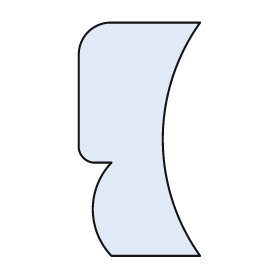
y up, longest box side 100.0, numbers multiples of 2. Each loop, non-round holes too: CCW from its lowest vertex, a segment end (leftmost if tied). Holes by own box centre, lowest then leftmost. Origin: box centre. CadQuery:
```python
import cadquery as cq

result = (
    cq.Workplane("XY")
    .moveTo(-12.0, -50.0)
    .lineTo(26.0, -50.0)
    .threePointArc((10.0, 0.0), (26.0, 50.0))
    .lineTo(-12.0, 50.0)
    .threePointArc((-22.0, 46.0), (-26.0, 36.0))
    .lineTo(-26.0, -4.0)
    .threePointArc((-24.0, -8.0), (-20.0, -10.0))
    .lineTo(-12.0, -10.0)
    .threePointArc((-20.0, -30.0), (-12.0, -50.0))
    .close()
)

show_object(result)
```